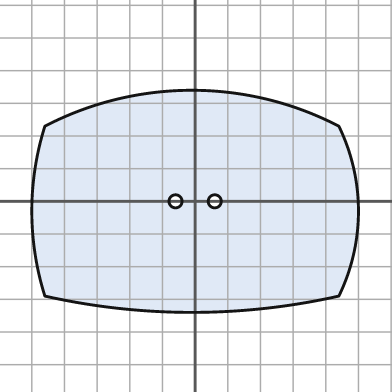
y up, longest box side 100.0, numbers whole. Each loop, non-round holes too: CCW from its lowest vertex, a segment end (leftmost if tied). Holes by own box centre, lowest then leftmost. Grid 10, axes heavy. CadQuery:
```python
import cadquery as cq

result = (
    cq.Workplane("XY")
    .moveTo(-46.0, -29.0)
    .threePointArc((-1.0, -34.0), (44.0, -29.0))
    .threePointArc((50.0, -3.0), (44.0, 23.0))
    .threePointArc((-1.0, 34.0), (-46.0, 23.0))
    .threePointArc((-50.0, -3.0), (-46.0, -29.0))
    .close()
    .moveTo(-6.0, 0.0)
    .circle(2.0)
    .moveTo(6.0, 0.0)
    .circle(2.0)
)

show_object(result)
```